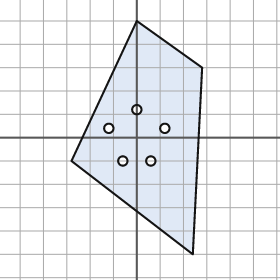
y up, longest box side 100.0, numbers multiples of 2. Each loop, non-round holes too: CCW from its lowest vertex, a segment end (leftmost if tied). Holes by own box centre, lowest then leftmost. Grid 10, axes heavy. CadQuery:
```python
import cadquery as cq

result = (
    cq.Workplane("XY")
    .moveTo(24.0, -50.0)
    .lineTo(28.0, 30.0)
    .lineTo(0.0, 50.0)
    .lineTo(-28.0, -10.0)
    .close()
    .moveTo(-6.0, -10.0)
    .circle(2.0)
    .moveTo(6.0, -10.0)
    .circle(2.0)
    .moveTo(-12.0, 4.0)
    .circle(2.0)
    .moveTo(12.0, 4.0)
    .circle(2.0)
    .moveTo(0.0, 12.0)
    .circle(2.0)
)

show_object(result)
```